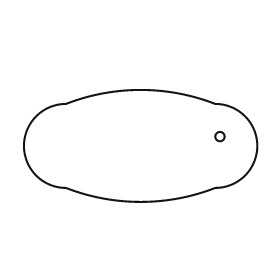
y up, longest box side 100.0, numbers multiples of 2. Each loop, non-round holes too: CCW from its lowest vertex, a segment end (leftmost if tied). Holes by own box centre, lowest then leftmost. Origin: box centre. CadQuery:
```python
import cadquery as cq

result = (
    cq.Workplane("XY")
    .moveTo(-32.0, -18.0)
    .threePointArc((0.0, -24.0), (32.0, -18.0))
    .threePointArc((50.0, 0.0), (32.0, 18.0))
    .threePointArc((0.0, 24.0), (-32.0, 18.0))
    .threePointArc((-50.0, 0.0), (-32.0, -18.0))
    .close()
    .moveTo(34.0, 4.0)
    .circle(2.0)
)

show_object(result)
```